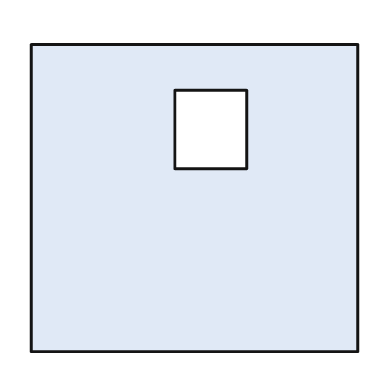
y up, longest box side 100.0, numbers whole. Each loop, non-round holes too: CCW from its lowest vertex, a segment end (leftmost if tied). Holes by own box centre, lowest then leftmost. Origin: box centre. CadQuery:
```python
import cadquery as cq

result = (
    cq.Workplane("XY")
    .moveTo(-50.0, -47.0)
    .lineTo(50.0, -47.0)
    .lineTo(50.0, 47.0)
    .lineTo(-50.0, 47.0)
    .close()
    .moveTo(-6.0, 9.0)
    .lineTo(16.0, 9.0)
    .lineTo(16.0, 33.0)
    .lineTo(-6.0, 33.0)
    .close()
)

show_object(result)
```